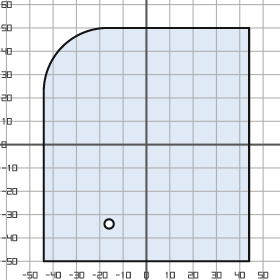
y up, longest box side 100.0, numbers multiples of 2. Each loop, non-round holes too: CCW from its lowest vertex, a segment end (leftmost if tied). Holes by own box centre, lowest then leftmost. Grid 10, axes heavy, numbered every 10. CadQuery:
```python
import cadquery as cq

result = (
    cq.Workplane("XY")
    .moveTo(-44.0, -50.0)
    .lineTo(44.0, -50.0)
    .lineTo(44.0, 50.0)
    .lineTo(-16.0, 50.0)
    .threePointArc((-36.0, 42.0), (-44.0, 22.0))
    .close()
    .moveTo(-16.0, -34.0)
    .circle(2.0)
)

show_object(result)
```